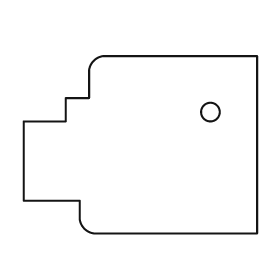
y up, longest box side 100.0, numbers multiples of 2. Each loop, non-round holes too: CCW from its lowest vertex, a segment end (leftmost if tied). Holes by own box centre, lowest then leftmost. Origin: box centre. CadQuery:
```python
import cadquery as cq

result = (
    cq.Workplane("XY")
    .moveTo(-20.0, -38.0)
    .lineTo(50.0, -38.0)
    .lineTo(50.0, 38.0)
    .lineTo(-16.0, 38.0)
    .threePointArc((-20.0, 36.0), (-22.0, 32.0))
    .lineTo(-22.0, 20.0)
    .lineTo(-32.0, 20.0)
    .lineTo(-32.0, 10.0)
    .lineTo(-50.0, 10.0)
    .lineTo(-50.0, -24.0)
    .lineTo(-26.0, -24.0)
    .lineTo(-26.0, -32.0)
    .threePointArc((-24.0, -36.0), (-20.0, -38.0))
    .close()
    .moveTo(30.0, 14.0)
    .circle(4.0)
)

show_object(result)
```